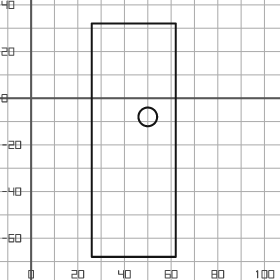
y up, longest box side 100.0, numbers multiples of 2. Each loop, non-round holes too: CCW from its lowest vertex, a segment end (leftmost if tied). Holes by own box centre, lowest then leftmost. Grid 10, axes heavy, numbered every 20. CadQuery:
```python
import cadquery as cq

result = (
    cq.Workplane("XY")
    .moveTo(26.0, -68.0)
    .lineTo(62.0, -68.0)
    .lineTo(62.0, 32.0)
    .lineTo(26.0, 32.0)
    .close()
    .moveTo(50.0, -8.0)
    .circle(4.0)
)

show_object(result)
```